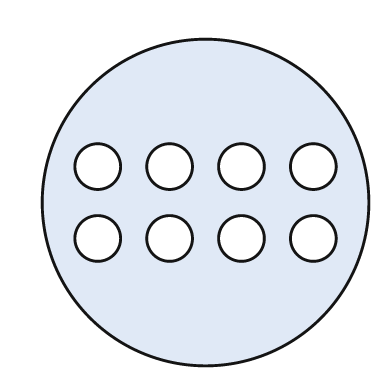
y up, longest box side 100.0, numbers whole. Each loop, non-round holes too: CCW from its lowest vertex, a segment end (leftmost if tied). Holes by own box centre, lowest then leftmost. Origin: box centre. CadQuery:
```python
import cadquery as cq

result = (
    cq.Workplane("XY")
    .moveTo(0.0, 0.0)
    .circle(50.0)
    .moveTo(-33.0, -11.0)
    .circle(7.0)
    .moveTo(-11.0, -11.0)
    .circle(7.0)
    .moveTo(11.0, -11.0)
    .circle(7.0)
    .moveTo(33.0, -11.0)
    .circle(7.0)
    .moveTo(-33.0, 11.0)
    .circle(7.0)
    .moveTo(-11.0, 11.0)
    .circle(7.0)
    .moveTo(11.0, 11.0)
    .circle(7.0)
    .moveTo(33.0, 11.0)
    .circle(7.0)
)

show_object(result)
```